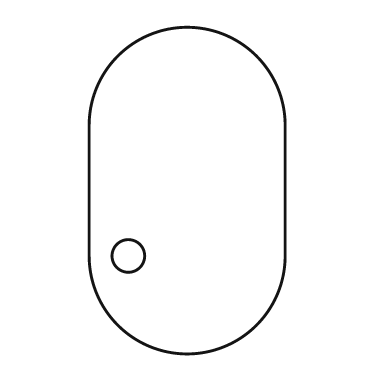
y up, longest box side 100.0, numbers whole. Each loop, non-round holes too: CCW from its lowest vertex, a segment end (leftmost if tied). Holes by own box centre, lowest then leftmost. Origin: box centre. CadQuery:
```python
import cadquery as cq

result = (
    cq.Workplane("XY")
    .moveTo(-30.0, -20.0)
    .threePointArc((0.0, -50.0), (30.0, -20.0))
    .lineTo(30.0, 20.0)
    .threePointArc((0.0, 50.0), (-30.0, 20.0))
    .close()
    .moveTo(-18.0, -20.0)
    .circle(5.0)
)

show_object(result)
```